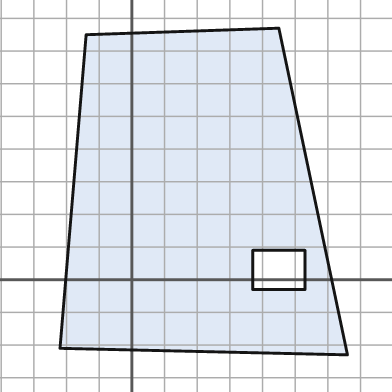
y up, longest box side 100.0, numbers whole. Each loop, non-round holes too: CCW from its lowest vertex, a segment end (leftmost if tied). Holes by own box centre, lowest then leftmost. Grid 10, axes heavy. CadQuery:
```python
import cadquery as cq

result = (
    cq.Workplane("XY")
    .moveTo(66.0, -23.0)
    .lineTo(45.0, 77.0)
    .lineTo(-14.0, 75.0)
    .lineTo(-22.0, -21.0)
    .close()
    .moveTo(37.0, -3.0)
    .lineTo(53.0, -3.0)
    .lineTo(53.0, 9.0)
    .lineTo(37.0, 9.0)
    .close()
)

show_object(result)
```